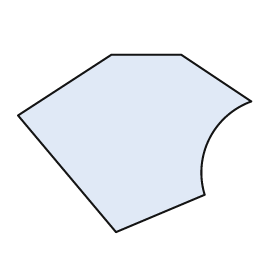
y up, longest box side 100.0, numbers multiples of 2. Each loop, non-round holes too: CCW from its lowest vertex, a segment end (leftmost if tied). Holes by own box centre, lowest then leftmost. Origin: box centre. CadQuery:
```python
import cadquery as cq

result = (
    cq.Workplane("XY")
    .moveTo(-8.0, -38.0)
    .lineTo(30.0, -22.0)
    .threePointArc((32.0, 2.0), (50.0, 18.0))
    .lineTo(20.0, 38.0)
    .lineTo(-10.0, 38.0)
    .lineTo(-50.0, 12.0)
    .close()
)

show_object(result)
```